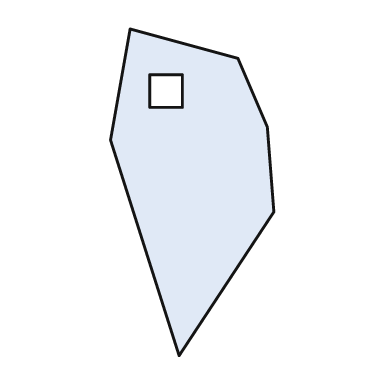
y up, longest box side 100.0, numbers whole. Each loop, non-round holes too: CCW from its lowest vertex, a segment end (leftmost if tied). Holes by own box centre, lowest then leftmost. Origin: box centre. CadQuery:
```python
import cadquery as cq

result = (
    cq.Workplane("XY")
    .moveTo(-4.0, -50.0)
    .lineTo(25.0, -6.0)
    .lineTo(23.0, 20.0)
    .lineTo(14.0, 41.0)
    .lineTo(-19.0, 50.0)
    .lineTo(-25.0, 16.0)
    .close()
    .moveTo(-13.0, 26.0)
    .lineTo(-3.0, 26.0)
    .lineTo(-3.0, 36.0)
    .lineTo(-13.0, 36.0)
    .close()
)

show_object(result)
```